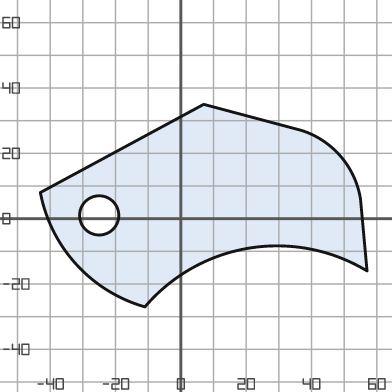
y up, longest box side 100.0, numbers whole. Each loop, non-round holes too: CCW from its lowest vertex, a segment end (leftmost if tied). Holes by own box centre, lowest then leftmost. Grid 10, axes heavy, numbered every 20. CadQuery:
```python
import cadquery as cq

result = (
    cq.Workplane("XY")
    .moveTo(-11.0, -27.0)
    .threePointArc((21.0, -9.0), (57.0, -16.0))
    .lineTo(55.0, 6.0)
    .threePointArc((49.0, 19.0), (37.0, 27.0))
    .lineTo(7.0, 35.0)
    .lineTo(-43.0, 8.0)
    .threePointArc((-32.0, -14.0), (-11.0, -27.0))
    .close()
    .moveTo(-25.0, 1.0)
    .circle(6.0)
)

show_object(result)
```